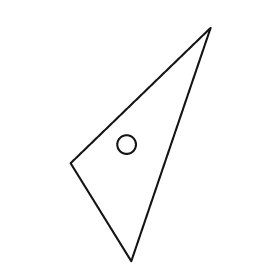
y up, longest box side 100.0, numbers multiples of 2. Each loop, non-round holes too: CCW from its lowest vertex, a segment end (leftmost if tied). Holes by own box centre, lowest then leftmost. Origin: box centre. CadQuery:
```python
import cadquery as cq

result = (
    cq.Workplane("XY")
    .moveTo(-4.0, -50.0)
    .lineTo(30.0, 50.0)
    .lineTo(-30.0, -8.0)
    .close()
    .moveTo(-6.0, 0.0)
    .circle(4.0)
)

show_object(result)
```